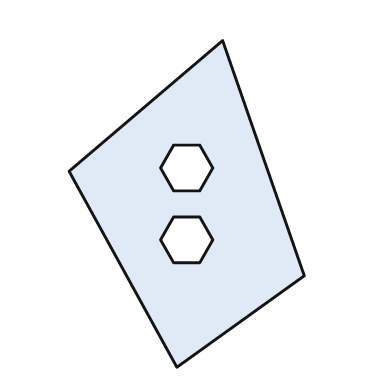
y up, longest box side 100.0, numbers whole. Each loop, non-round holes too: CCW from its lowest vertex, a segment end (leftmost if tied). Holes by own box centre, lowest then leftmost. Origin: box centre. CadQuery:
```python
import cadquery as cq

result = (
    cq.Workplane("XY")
    .moveTo(-3.0, -50.0)
    .lineTo(36.0, -22.0)
    .lineTo(11.0, 50.0)
    .lineTo(-36.0, 10.0)
    .close()
    .moveTo(-4.0, -18.0)
    .lineTo(4.0, -18.0)
    .lineTo(8.0, -11.0)
    .lineTo(4.0, -4.0)
    .lineTo(-4.0, -4.0)
    .lineTo(-8.0, -11.0)
    .close()
    .moveTo(-4.0, 4.0)
    .lineTo(4.0, 4.0)
    .lineTo(8.0, 11.0)
    .lineTo(4.0, 18.0)
    .lineTo(-4.0, 18.0)
    .lineTo(-8.0, 11.0)
    .close()
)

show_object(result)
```